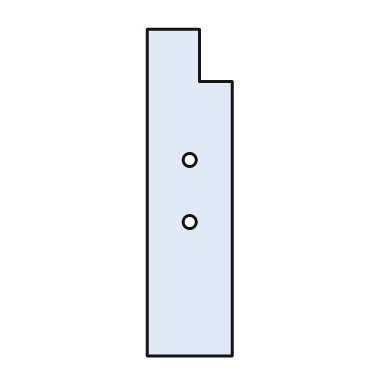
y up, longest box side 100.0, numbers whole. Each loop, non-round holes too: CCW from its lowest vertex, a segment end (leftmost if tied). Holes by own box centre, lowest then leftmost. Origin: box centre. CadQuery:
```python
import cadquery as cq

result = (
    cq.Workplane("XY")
    .moveTo(-13.0, -50.0)
    .lineTo(13.0, -50.0)
    .lineTo(13.0, 34.0)
    .lineTo(3.0, 34.0)
    .lineTo(3.0, 50.0)
    .lineTo(-13.0, 50.0)
    .close()
    .moveTo(0.0, -9.0)
    .circle(2.0)
    .moveTo(0.0, 10.0)
    .circle(2.0)
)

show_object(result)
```